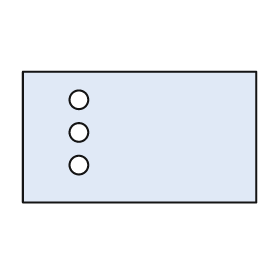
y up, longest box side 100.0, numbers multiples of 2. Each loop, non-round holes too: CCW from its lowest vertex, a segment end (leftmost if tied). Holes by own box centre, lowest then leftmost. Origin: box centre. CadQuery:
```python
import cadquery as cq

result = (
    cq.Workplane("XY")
    .moveTo(-50.0, -28.0)
    .lineTo(50.0, -28.0)
    .lineTo(50.0, 28.0)
    .lineTo(-50.0, 28.0)
    .close()
    .moveTo(-26.0, -12.0)
    .circle(4.0)
    .moveTo(-26.0, 2.0)
    .circle(4.0)
    .moveTo(-26.0, 16.0)
    .circle(4.0)
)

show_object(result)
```